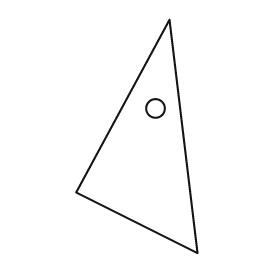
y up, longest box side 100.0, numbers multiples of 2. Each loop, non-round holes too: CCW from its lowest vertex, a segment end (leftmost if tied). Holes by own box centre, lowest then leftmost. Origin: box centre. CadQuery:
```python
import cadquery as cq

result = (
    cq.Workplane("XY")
    .moveTo(26.0, -50.0)
    .lineTo(14.0, 50.0)
    .lineTo(-26.0, -24.0)
    .close()
    .moveTo(8.0, 12.0)
    .circle(4.0)
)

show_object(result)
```